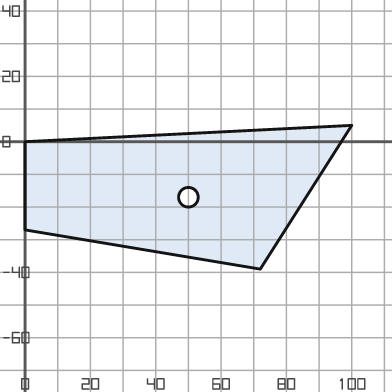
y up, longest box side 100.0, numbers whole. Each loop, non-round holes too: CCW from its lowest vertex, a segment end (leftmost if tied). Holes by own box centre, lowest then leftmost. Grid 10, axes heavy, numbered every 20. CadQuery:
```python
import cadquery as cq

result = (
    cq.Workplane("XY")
    .moveTo(72.0, -39.0)
    .lineTo(100.0, 5.0)
    .lineTo(0.0, 0.0)
    .lineTo(0.0, -27.0)
    .close()
    .moveTo(50.0, -17.0)
    .circle(3.0)
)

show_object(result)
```